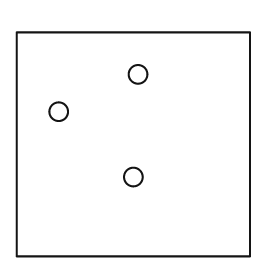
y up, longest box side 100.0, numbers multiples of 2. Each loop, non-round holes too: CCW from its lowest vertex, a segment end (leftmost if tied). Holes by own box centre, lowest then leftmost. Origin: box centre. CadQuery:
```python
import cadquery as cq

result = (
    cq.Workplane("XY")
    .moveTo(-50.0, -48.0)
    .lineTo(50.0, -48.0)
    .lineTo(50.0, 48.0)
    .lineTo(-50.0, 48.0)
    .close()
    .moveTo(0.0, -14.0)
    .circle(4.0)
    .moveTo(-32.0, 14.0)
    .circle(4.0)
    .moveTo(2.0, 30.0)
    .circle(4.0)
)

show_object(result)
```